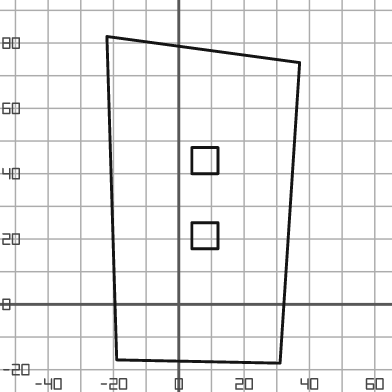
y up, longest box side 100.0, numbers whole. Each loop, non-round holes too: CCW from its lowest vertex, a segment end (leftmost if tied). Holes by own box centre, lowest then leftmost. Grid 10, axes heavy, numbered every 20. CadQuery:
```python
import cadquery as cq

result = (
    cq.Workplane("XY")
    .moveTo(31.0, -18.0)
    .lineTo(37.0, 74.0)
    .lineTo(-22.0, 82.0)
    .lineTo(-19.0, -17.0)
    .close()
    .moveTo(4.0, 17.0)
    .lineTo(12.0, 17.0)
    .lineTo(12.0, 25.0)
    .lineTo(4.0, 25.0)
    .close()
    .moveTo(4.0, 40.0)
    .lineTo(12.0, 40.0)
    .lineTo(12.0, 48.0)
    .lineTo(4.0, 48.0)
    .close()
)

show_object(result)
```